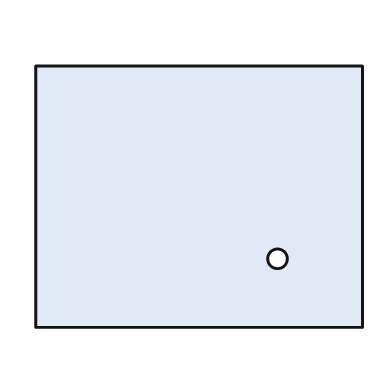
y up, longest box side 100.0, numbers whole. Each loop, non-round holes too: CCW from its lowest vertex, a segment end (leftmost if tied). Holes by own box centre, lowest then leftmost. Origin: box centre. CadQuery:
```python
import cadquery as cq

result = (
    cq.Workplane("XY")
    .moveTo(-50.0, -40.0)
    .lineTo(50.0, -40.0)
    .lineTo(50.0, 40.0)
    .lineTo(-50.0, 40.0)
    .close()
    .moveTo(24.0, -19.0)
    .circle(3.0)
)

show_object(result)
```